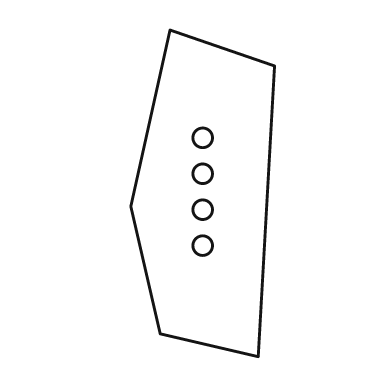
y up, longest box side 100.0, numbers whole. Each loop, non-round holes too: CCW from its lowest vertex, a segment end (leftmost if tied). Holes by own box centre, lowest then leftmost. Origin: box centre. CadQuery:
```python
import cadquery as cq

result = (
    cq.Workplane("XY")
    .moveTo(17.0, -50.0)
    .lineTo(22.0, 39.0)
    .lineTo(-10.0, 50.0)
    .lineTo(-22.0, -4.0)
    .lineTo(-13.0, -43.0)
    .close()
    .moveTo(0.0, -16.0)
    .circle(3.0)
    .moveTo(0.0, -5.0)
    .circle(3.0)
    .moveTo(0.0, 6.0)
    .circle(3.0)
    .moveTo(0.0, 17.0)
    .circle(3.0)
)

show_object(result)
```